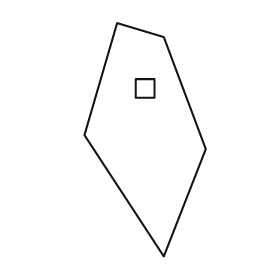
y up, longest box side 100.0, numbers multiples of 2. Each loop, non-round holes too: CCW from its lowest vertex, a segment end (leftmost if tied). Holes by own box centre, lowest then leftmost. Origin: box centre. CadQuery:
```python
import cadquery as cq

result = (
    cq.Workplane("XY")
    .moveTo(8.0, -50.0)
    .lineTo(26.0, -4.0)
    .lineTo(8.0, 44.0)
    .lineTo(-12.0, 50.0)
    .lineTo(-26.0, 2.0)
    .close()
    .moveTo(-4.0, 18.0)
    .lineTo(4.0, 18.0)
    .lineTo(4.0, 26.0)
    .lineTo(-4.0, 26.0)
    .close()
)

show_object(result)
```